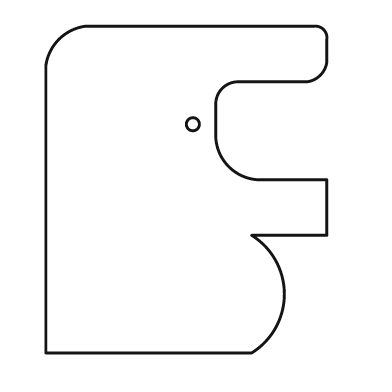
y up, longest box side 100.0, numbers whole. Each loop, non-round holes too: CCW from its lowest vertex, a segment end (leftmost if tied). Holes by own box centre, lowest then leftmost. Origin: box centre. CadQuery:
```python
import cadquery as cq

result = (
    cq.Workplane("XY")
    .moveTo(-43.0, -50.0)
    .lineTo(20.0, -50.0)
    .threePointArc((30.0, -32.0), (20.0, -14.0))
    .lineTo(43.0, -14.0)
    .lineTo(43.0, 3.0)
    .lineTo(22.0, 3.0)
    .threePointArc((13.0, 7.0), (9.0, 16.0))
    .lineTo(9.0, 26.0)
    .threePointArc((11.0, 31.0), (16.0, 33.0))
    .lineTo(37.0, 33.0)
    .threePointArc((41.0, 35.0), (43.0, 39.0))
    .lineTo(43.0, 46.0)
    .threePointArc((42.0, 49.0), (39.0, 50.0))
    .lineTo(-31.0, 50.0)
    .threePointArc((-39.0, 46.0), (-43.0, 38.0))
    .close()
    .moveTo(2.0, 20.0)
    .circle(2.0)
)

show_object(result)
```